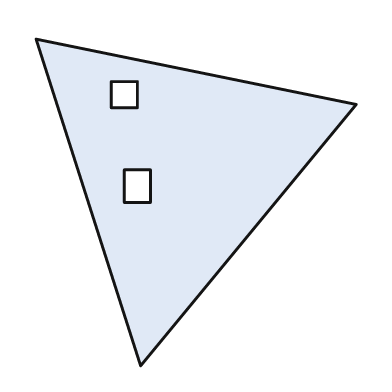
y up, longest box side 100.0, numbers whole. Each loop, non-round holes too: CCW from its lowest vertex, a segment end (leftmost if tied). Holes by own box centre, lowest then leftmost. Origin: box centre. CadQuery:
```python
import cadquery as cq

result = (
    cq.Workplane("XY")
    .moveTo(-17.0, -50.0)
    .lineTo(49.0, 30.0)
    .lineTo(-49.0, 50.0)
    .close()
    .moveTo(-22.0, 0.0)
    .lineTo(-14.0, 0.0)
    .lineTo(-14.0, 10.0)
    .lineTo(-22.0, 10.0)
    .close()
    .moveTo(-26.0, 29.0)
    .lineTo(-18.0, 29.0)
    .lineTo(-18.0, 37.0)
    .lineTo(-26.0, 37.0)
    .close()
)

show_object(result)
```